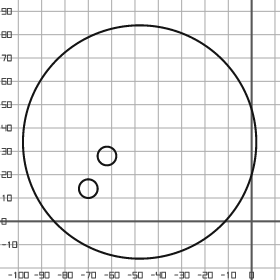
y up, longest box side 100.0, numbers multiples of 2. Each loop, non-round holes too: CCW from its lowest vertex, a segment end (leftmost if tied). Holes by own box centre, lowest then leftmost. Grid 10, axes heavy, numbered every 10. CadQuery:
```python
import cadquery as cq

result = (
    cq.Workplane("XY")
    .moveTo(-48.0, 34.0)
    .circle(50.0)
    .moveTo(-70.0, 14.0)
    .circle(4.0)
    .moveTo(-62.0, 28.0)
    .circle(4.0)
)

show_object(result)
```